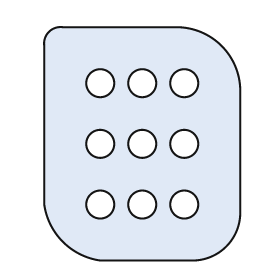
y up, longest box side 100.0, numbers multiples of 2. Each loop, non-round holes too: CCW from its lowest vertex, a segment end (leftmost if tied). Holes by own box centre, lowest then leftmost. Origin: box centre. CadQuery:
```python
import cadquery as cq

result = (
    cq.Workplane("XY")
    .moveTo(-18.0, -50.0)
    .lineTo(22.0, -50.0)
    .threePointArc((36.0, -44.0), (42.0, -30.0))
    .lineTo(42.0, 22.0)
    .threePointArc((34.0, 42.0), (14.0, 50.0))
    .lineTo(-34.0, 50.0)
    .threePointArc((-40.0, 48.0), (-42.0, 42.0))
    .lineTo(-42.0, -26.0)
    .threePointArc((-34.0, -42.0), (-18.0, -50.0))
    .close()
    .moveTo(-18.0, -26.0)
    .circle(6.0)
    .moveTo(0.0, -26.0)
    .circle(6.0)
    .moveTo(18.0, -26.0)
    .circle(6.0)
    .moveTo(-18.0, 0.0)
    .circle(6.0)
    .moveTo(0.0, 0.0)
    .circle(6.0)
    .moveTo(18.0, 0.0)
    .circle(6.0)
    .moveTo(-18.0, 26.0)
    .circle(6.0)
    .moveTo(0.0, 26.0)
    .circle(6.0)
    .moveTo(18.0, 26.0)
    .circle(6.0)
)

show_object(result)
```